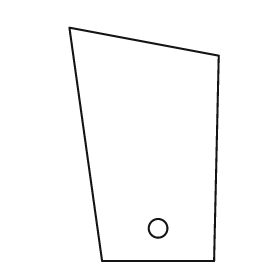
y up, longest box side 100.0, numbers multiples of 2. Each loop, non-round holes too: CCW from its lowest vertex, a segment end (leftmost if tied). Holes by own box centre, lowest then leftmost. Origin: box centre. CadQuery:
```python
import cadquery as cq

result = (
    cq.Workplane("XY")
    .moveTo(-18.0, -50.0)
    .lineTo(30.0, -50.0)
    .lineTo(32.0, 38.0)
    .lineTo(-32.0, 50.0)
    .close()
    .moveTo(6.0, -36.0)
    .circle(4.0)
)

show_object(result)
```